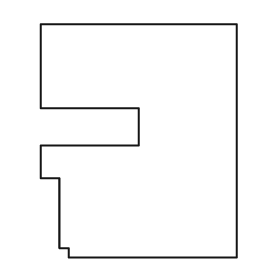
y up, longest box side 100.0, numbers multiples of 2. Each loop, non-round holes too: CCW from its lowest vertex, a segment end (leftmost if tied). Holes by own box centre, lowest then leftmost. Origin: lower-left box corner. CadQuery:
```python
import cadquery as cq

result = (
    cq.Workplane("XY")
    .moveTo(12.0, 0.0)
    .lineTo(84.0, 0.0)
    .lineTo(84.0, 100.0)
    .lineTo(0.0, 100.0)
    .lineTo(0.0, 64.0)
    .lineTo(42.0, 64.0)
    .lineTo(42.0, 48.0)
    .lineTo(0.0, 48.0)
    .lineTo(0.0, 34.0)
    .lineTo(8.0, 34.0)
    .lineTo(8.0, 4.0)
    .lineTo(12.0, 4.0)
    .close()
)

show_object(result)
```